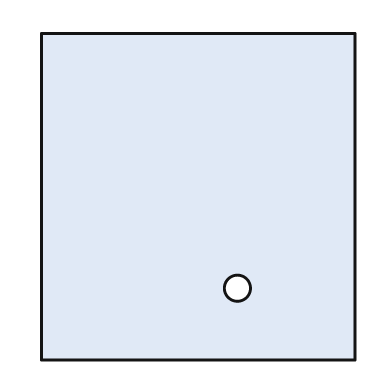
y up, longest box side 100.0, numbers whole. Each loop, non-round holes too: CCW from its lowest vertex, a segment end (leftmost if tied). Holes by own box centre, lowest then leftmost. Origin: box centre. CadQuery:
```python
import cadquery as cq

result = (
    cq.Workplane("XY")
    .moveTo(-48.0, -50.0)
    .lineTo(48.0, -50.0)
    .lineTo(48.0, 50.0)
    .lineTo(-48.0, 50.0)
    .close()
    .moveTo(12.0, -28.0)
    .circle(4.0)
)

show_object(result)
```